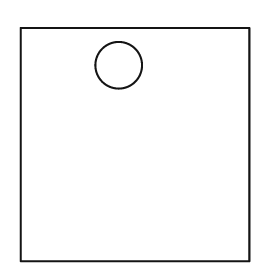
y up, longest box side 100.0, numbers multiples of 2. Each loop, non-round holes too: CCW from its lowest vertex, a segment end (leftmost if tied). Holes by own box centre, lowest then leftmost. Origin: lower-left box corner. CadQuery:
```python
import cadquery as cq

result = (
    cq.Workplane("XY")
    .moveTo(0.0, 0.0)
    .lineTo(98.0, 0.0)
    .lineTo(98.0, 100.0)
    .lineTo(0.0, 100.0)
    .close()
    .moveTo(42.0, 84.0)
    .circle(10.0)
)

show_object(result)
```